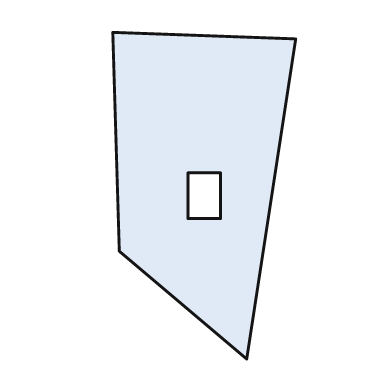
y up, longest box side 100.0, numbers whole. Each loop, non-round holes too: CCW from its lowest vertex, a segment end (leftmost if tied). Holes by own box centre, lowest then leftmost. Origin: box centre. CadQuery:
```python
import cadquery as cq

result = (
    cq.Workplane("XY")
    .moveTo(13.0, -50.0)
    .lineTo(28.0, 48.0)
    .lineTo(-28.0, 50.0)
    .lineTo(-26.0, -17.0)
    .close()
    .moveTo(-5.0, -7.0)
    .lineTo(5.0, -7.0)
    .lineTo(5.0, 7.0)
    .lineTo(-5.0, 7.0)
    .close()
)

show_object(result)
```